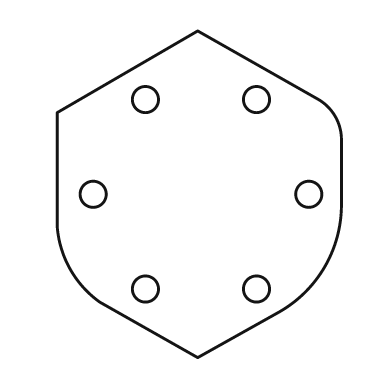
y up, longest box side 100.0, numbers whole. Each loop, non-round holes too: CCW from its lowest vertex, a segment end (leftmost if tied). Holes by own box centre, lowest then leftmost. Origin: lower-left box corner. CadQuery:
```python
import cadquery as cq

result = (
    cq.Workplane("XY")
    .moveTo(43.0, 0.0)
    .lineTo(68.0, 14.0)
    .threePointArc((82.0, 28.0), (87.0, 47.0))
    .lineTo(87.0, 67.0)
    .threePointArc((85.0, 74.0), (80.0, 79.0))
    .lineTo(43.0, 100.0)
    .lineTo(0.0, 75.0)
    .lineTo(0.0, 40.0)
    .threePointArc((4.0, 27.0), (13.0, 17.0))
    .close()
    .moveTo(27.0, 21.0)
    .circle(4.0)
    .moveTo(61.0, 21.0)
    .circle(4.0)
    .moveTo(11.0, 50.0)
    .circle(4.0)
    .moveTo(77.0, 50.0)
    .circle(4.0)
    .moveTo(27.0, 79.0)
    .circle(4.0)
    .moveTo(61.0, 79.0)
    .circle(4.0)
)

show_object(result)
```